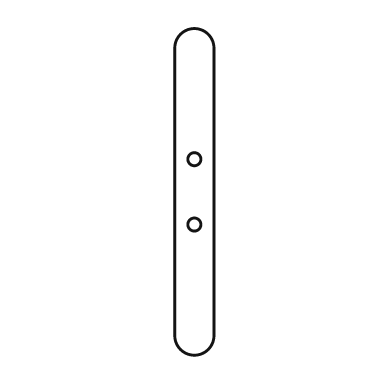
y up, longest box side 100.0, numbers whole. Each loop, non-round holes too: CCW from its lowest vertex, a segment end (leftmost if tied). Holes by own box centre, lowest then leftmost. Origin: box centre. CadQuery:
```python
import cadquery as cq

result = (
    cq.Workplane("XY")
    .moveTo(-6.0, -44.0)
    .threePointArc((0.0, -50.0), (6.0, -44.0))
    .lineTo(6.0, 44.0)
    .threePointArc((0.0, 50.0), (-6.0, 44.0))
    .close()
    .moveTo(0.0, -10.0)
    .circle(2.0)
    .moveTo(0.0, 10.0)
    .circle(2.0)
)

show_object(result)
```